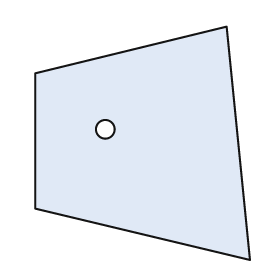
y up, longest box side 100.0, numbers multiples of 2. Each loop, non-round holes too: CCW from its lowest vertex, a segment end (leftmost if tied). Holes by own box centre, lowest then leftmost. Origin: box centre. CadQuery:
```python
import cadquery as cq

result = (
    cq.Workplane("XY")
    .moveTo(46.0, -50.0)
    .lineTo(36.0, 50.0)
    .lineTo(-46.0, 30.0)
    .lineTo(-46.0, -28.0)
    .close()
    .moveTo(-16.0, 6.0)
    .circle(4.0)
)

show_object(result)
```